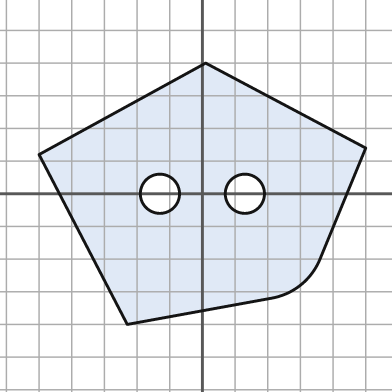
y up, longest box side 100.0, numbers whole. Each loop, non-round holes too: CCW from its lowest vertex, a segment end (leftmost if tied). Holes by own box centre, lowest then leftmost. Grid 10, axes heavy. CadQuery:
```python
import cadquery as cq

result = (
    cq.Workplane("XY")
    .moveTo(-23.0, -40.0)
    .lineTo(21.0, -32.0)
    .threePointArc((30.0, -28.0), (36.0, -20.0))
    .lineTo(50.0, 14.0)
    .lineTo(1.0, 40.0)
    .lineTo(-50.0, 12.0)
    .close()
    .moveTo(-13.0, 0.0)
    .circle(6.0)
    .moveTo(13.0, 0.0)
    .circle(6.0)
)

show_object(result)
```